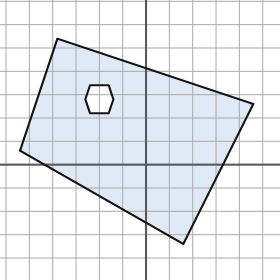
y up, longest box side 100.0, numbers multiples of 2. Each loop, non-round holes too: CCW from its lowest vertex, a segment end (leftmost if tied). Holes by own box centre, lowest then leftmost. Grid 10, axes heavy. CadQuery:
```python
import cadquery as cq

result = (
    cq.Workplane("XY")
    .moveTo(16.0, -34.0)
    .lineTo(46.0, 26.0)
    .lineTo(-38.0, 54.0)
    .lineTo(-54.0, 6.0)
    .close()
    .moveTo(-24.0, 22.0)
    .lineTo(-16.0, 22.0)
    .lineTo(-14.0, 28.0)
    .lineTo(-16.0, 34.0)
    .lineTo(-24.0, 34.0)
    .lineTo(-26.0, 28.0)
    .close()
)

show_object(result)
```